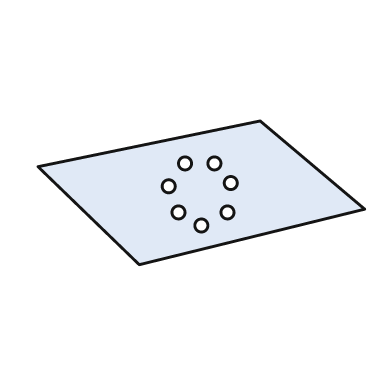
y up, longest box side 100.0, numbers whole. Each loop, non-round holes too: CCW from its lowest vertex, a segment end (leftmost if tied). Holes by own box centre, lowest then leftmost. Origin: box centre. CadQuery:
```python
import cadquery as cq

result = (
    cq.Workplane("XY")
    .moveTo(-19.0, -22.0)
    .lineTo(50.0, -5.0)
    .lineTo(18.0, 22.0)
    .lineTo(-50.0, 8.0)
    .close()
    .moveTo(0.0, -10.0)
    .circle(2.0)
    .moveTo(-7.0, -6.0)
    .circle(2.0)
    .moveTo(8.0, -6.0)
    .circle(2.0)
    .moveTo(-10.0, 2.0)
    .circle(2.0)
    .moveTo(9.0, 3.0)
    .circle(2.0)
    .moveTo(-5.0, 9.0)
    .circle(2.0)
    .moveTo(4.0, 9.0)
    .circle(2.0)
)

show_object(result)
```